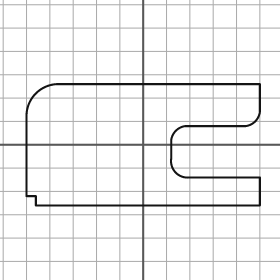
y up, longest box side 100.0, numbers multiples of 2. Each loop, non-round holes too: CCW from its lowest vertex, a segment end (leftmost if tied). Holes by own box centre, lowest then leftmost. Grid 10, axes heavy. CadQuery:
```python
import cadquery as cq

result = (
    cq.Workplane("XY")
    .moveTo(-46.0, -26.0)
    .lineTo(50.0, -26.0)
    .lineTo(50.0, -14.0)
    .lineTo(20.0, -14.0)
    .threePointArc((14.0, -12.0), (12.0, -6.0))
    .lineTo(12.0, 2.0)
    .threePointArc((14.0, 6.0), (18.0, 8.0))
    .lineTo(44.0, 8.0)
    .threePointArc((48.0, 10.0), (50.0, 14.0))
    .lineTo(50.0, 26.0)
    .lineTo(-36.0, 26.0)
    .threePointArc((-46.0, 22.0), (-50.0, 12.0))
    .lineTo(-50.0, -22.0)
    .lineTo(-46.0, -22.0)
    .close()
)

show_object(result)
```